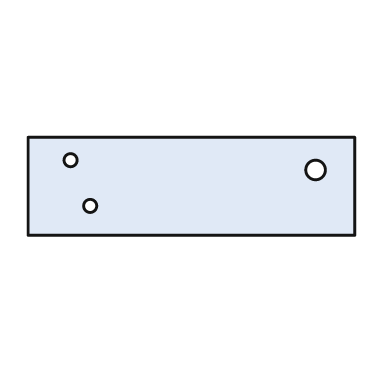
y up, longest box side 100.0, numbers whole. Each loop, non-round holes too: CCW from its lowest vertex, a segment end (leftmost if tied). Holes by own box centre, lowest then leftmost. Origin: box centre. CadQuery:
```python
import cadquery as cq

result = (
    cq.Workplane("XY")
    .moveTo(-50.0, -15.0)
    .lineTo(50.0, -15.0)
    .lineTo(50.0, 15.0)
    .lineTo(-50.0, 15.0)
    .close()
    .moveTo(-31.0, -6.0)
    .circle(2.0)
    .moveTo(38.0, 5.0)
    .circle(3.0)
    .moveTo(-37.0, 8.0)
    .circle(2.0)
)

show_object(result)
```